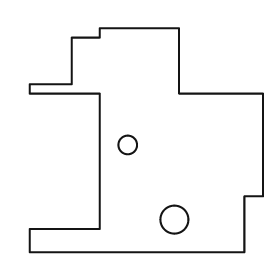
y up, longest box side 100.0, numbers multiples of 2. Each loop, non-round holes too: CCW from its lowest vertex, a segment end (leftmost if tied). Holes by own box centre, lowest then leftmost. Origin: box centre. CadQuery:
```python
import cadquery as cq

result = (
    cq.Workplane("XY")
    .moveTo(-50.0, -48.0)
    .lineTo(42.0, -48.0)
    .lineTo(42.0, -24.0)
    .lineTo(50.0, -24.0)
    .lineTo(50.0, 20.0)
    .lineTo(14.0, 20.0)
    .lineTo(14.0, 48.0)
    .lineTo(-20.0, 48.0)
    .lineTo(-20.0, 44.0)
    .lineTo(-32.0, 44.0)
    .lineTo(-32.0, 24.0)
    .lineTo(-50.0, 24.0)
    .lineTo(-50.0, 20.0)
    .lineTo(-20.0, 20.0)
    .lineTo(-20.0, -38.0)
    .lineTo(-50.0, -38.0)
    .close()
    .moveTo(12.0, -34.0)
    .circle(6.0)
    .moveTo(-8.0, -2.0)
    .circle(4.0)
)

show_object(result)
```